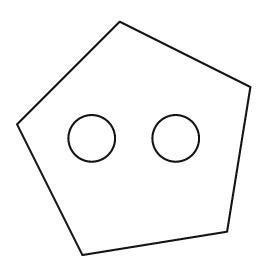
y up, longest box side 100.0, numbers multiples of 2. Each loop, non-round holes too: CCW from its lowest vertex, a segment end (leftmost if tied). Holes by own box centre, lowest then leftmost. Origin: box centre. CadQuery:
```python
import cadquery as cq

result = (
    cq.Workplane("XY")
    .moveTo(-22.0, -50.0)
    .lineTo(40.0, -40.0)
    .lineTo(50.0, 22.0)
    .lineTo(-6.0, 50.0)
    .lineTo(-50.0, 6.0)
    .close()
    .moveTo(-18.0, 0.0)
    .circle(10.0)
    .moveTo(18.0, 0.0)
    .circle(10.0)
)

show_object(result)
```